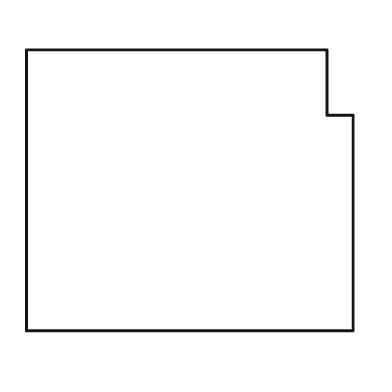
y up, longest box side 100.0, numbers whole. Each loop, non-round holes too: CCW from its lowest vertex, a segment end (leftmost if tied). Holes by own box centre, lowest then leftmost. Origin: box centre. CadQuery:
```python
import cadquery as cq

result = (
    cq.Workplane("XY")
    .moveTo(-50.0, -43.0)
    .lineTo(50.0, -43.0)
    .lineTo(50.0, 23.0)
    .lineTo(42.0, 23.0)
    .lineTo(42.0, 43.0)
    .lineTo(-50.0, 43.0)
    .close()
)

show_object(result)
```